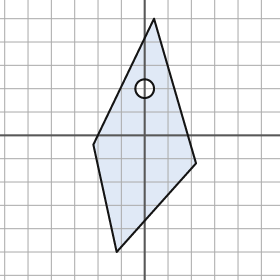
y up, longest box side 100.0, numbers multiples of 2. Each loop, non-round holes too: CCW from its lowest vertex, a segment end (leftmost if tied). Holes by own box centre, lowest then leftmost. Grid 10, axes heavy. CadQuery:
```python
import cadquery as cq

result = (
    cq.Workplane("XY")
    .moveTo(-12.0, -50.0)
    .lineTo(22.0, -12.0)
    .lineTo(4.0, 50.0)
    .lineTo(-22.0, -4.0)
    .close()
    .moveTo(0.0, 20.0)
    .circle(4.0)
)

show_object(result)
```